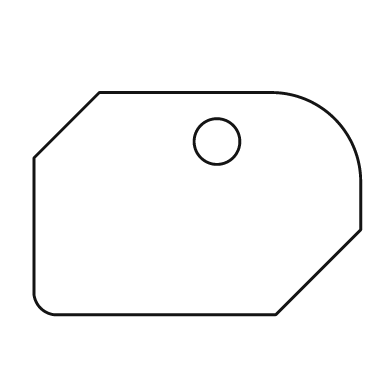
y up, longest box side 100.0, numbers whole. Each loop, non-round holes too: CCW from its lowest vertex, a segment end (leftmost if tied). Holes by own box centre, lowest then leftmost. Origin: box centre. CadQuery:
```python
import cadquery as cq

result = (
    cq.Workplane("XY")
    .moveTo(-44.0, -34.0)
    .lineTo(24.0, -34.0)
    .lineTo(50.0, -8.0)
    .lineTo(50.0, 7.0)
    .threePointArc((42.0, 26.0), (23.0, 34.0))
    .lineTo(-30.0, 34.0)
    .lineTo(-50.0, 14.0)
    .lineTo(-50.0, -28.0)
    .threePointArc((-48.0, -32.0), (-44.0, -34.0))
    .close()
    .moveTo(6.0, 19.0)
    .circle(7.0)
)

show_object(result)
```